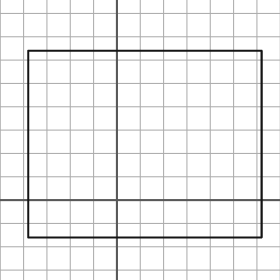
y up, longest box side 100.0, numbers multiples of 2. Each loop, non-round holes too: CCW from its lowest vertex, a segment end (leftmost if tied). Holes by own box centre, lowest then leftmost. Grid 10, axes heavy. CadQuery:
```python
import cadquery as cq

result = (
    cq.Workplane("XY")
    .moveTo(-38.0, -16.0)
    .lineTo(62.0, -16.0)
    .lineTo(62.0, 64.0)
    .lineTo(-38.0, 64.0)
    .close()
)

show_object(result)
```